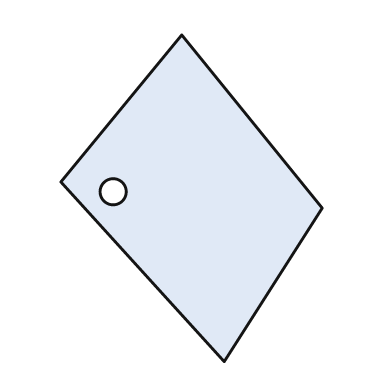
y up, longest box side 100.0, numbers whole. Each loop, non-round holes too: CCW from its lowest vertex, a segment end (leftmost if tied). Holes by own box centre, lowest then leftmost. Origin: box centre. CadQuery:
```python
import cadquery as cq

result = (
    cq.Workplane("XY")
    .moveTo(10.0, -50.0)
    .lineTo(40.0, -3.0)
    .lineTo(-3.0, 50.0)
    .lineTo(-40.0, 5.0)
    .close()
    .moveTo(-24.0, 2.0)
    .circle(4.0)
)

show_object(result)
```